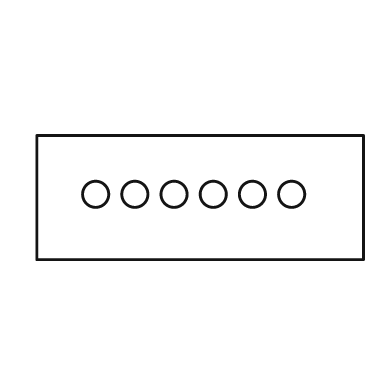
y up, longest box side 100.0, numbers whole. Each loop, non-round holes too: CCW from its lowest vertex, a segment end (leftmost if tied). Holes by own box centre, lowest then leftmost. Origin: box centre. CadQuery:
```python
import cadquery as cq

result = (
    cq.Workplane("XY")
    .moveTo(-50.0, -19.0)
    .lineTo(50.0, -19.0)
    .lineTo(50.0, 19.0)
    .lineTo(-50.0, 19.0)
    .close()
    .moveTo(-32.0, 1.0)
    .circle(4.0)
    .moveTo(-20.0, 1.0)
    .circle(4.0)
    .moveTo(-8.0, 1.0)
    .circle(4.0)
    .moveTo(4.0, 1.0)
    .circle(4.0)
    .moveTo(16.0, 1.0)
    .circle(4.0)
    .moveTo(28.0, 1.0)
    .circle(4.0)
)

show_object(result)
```